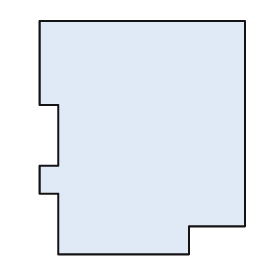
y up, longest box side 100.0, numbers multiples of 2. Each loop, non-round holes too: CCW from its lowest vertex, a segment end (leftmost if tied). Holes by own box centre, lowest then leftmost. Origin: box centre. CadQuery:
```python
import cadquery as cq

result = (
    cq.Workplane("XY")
    .moveTo(-36.0, -50.0)
    .lineTo(20.0, -50.0)
    .lineTo(20.0, -38.0)
    .lineTo(44.0, -38.0)
    .lineTo(44.0, 50.0)
    .lineTo(-44.0, 50.0)
    .lineTo(-44.0, 14.0)
    .lineTo(-36.0, 14.0)
    .lineTo(-36.0, -12.0)
    .lineTo(-44.0, -12.0)
    .lineTo(-44.0, -24.0)
    .lineTo(-36.0, -24.0)
    .close()
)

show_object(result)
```